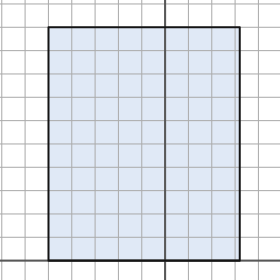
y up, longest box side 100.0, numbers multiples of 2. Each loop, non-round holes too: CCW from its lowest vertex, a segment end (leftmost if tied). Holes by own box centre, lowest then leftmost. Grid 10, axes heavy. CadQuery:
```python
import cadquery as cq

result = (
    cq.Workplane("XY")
    .moveTo(-50.0, 0.0)
    .lineTo(32.0, 0.0)
    .lineTo(32.0, 100.0)
    .lineTo(-50.0, 100.0)
    .close()
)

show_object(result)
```